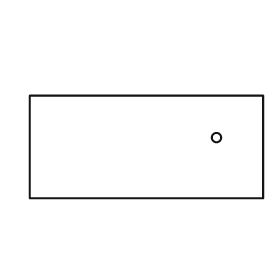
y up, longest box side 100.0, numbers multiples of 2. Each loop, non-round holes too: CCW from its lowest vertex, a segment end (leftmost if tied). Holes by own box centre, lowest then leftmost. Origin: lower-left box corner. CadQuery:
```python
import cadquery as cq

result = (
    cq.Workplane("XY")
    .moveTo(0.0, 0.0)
    .lineTo(100.0, 0.0)
    .lineTo(100.0, 44.0)
    .lineTo(0.0, 44.0)
    .close()
    .moveTo(80.0, 26.0)
    .circle(2.0)
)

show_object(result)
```